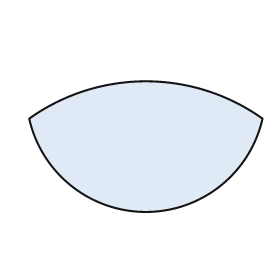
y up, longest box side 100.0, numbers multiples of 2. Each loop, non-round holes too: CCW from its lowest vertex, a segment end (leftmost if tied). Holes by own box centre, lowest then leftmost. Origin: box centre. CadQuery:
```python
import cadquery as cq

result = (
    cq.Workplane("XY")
    .moveTo(-50.0, 12.0)
    .threePointArc((0.0, -28.0), (50.0, 12.0))
    .threePointArc((0.0, 28.0), (-50.0, 12.0))
    .close()
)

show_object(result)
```